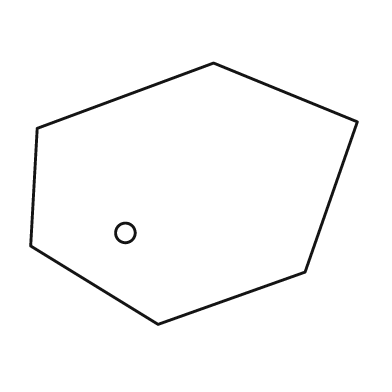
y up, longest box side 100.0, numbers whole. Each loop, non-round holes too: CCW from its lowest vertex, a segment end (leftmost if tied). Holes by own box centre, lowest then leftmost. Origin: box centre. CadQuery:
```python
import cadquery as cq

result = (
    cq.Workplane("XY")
    .moveTo(-11.0, -40.0)
    .lineTo(34.0, -24.0)
    .lineTo(50.0, 22.0)
    .lineTo(6.0, 40.0)
    .lineTo(-48.0, 20.0)
    .lineTo(-50.0, -16.0)
    .close()
    .moveTo(-21.0, -12.0)
    .circle(3.0)
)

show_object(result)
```